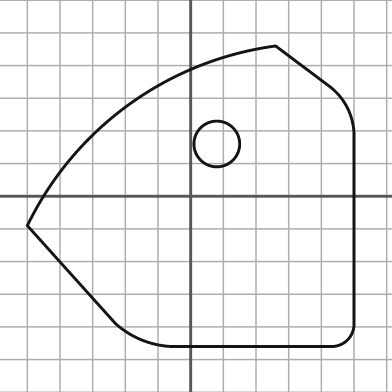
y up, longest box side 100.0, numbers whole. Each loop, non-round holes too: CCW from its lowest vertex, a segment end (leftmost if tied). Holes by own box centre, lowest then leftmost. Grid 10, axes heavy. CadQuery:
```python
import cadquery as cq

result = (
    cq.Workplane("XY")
    .moveTo(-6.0, -46.0)
    .lineTo(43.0, -46.0)
    .threePointArc((48.0, -44.0), (50.0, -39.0))
    .lineTo(50.0, 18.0)
    .threePointArc((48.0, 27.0), (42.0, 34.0))
    .lineTo(26.0, 46.0)
    .threePointArc((-19.0, 28.0), (-50.0, -9.0))
    .lineTo(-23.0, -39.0)
    .threePointArc((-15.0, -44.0), (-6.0, -46.0))
    .close()
    .moveTo(8.0, 16.0)
    .circle(7.0)
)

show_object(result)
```